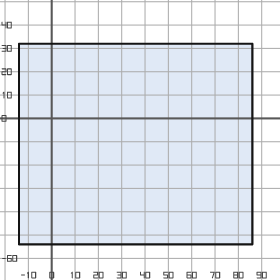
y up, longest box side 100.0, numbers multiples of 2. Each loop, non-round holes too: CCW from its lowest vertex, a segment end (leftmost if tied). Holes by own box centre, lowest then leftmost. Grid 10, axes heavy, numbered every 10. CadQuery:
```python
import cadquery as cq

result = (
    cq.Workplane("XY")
    .moveTo(-14.0, -54.0)
    .lineTo(86.0, -54.0)
    .lineTo(86.0, 32.0)
    .lineTo(-14.0, 32.0)
    .close()
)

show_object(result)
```